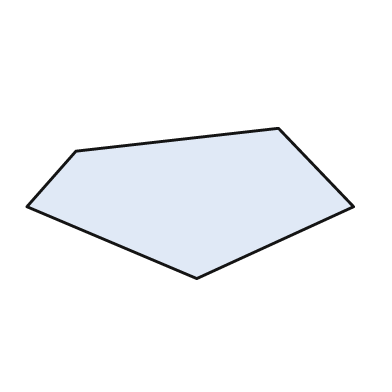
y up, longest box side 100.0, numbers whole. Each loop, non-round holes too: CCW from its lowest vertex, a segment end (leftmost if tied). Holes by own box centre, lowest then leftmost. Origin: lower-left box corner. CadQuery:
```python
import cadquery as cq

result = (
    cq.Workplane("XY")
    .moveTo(52.0, 0.0)
    .lineTo(100.0, 22.0)
    .lineTo(77.0, 46.0)
    .lineTo(15.0, 39.0)
    .lineTo(0.0, 22.0)
    .close()
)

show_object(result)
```